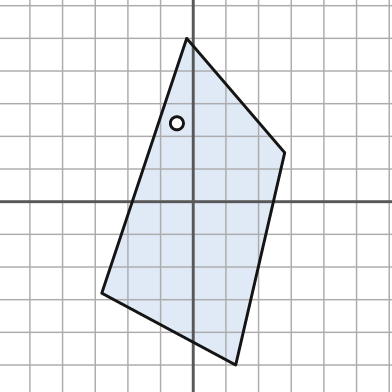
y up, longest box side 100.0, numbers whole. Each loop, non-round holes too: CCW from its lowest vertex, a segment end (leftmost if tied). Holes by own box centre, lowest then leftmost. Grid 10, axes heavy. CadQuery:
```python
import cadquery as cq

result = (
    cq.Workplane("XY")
    .moveTo(13.0, -50.0)
    .lineTo(28.0, 15.0)
    .lineTo(-2.0, 50.0)
    .lineTo(-28.0, -28.0)
    .close()
    .moveTo(-5.0, 24.0)
    .circle(2.0)
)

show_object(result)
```